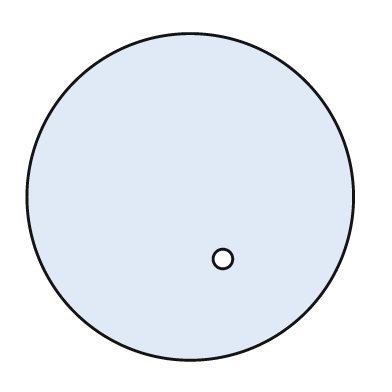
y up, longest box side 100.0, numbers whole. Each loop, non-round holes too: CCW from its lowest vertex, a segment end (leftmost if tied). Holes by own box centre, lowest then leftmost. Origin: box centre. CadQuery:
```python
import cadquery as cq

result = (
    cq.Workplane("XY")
    .moveTo(0.0, 0.0)
    .circle(50.0)
    .moveTo(10.0, -19.0)
    .circle(3.0)
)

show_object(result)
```